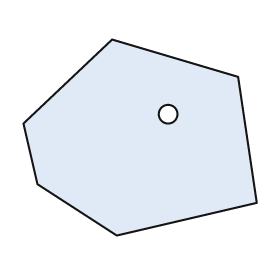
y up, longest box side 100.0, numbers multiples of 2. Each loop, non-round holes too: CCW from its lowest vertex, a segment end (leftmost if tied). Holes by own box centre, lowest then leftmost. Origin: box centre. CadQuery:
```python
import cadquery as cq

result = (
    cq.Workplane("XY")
    .moveTo(-10.0, -42.0)
    .lineTo(50.0, -28.0)
    .lineTo(42.0, 26.0)
    .lineTo(-12.0, 42.0)
    .lineTo(-50.0, 6.0)
    .lineTo(-44.0, -20.0)
    .close()
    .moveTo(12.0, 10.0)
    .circle(4.0)
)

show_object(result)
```